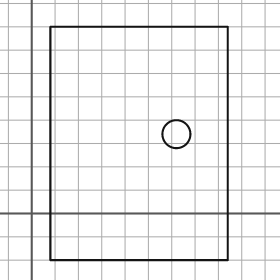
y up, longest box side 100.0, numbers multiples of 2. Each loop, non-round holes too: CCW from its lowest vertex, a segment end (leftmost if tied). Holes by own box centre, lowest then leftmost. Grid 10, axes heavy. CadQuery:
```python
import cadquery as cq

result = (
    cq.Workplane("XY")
    .moveTo(8.0, -20.0)
    .lineTo(84.0, -20.0)
    .lineTo(84.0, 80.0)
    .lineTo(8.0, 80.0)
    .close()
    .moveTo(62.0, 34.0)
    .circle(6.0)
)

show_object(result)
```